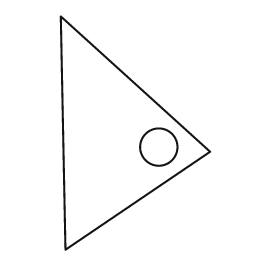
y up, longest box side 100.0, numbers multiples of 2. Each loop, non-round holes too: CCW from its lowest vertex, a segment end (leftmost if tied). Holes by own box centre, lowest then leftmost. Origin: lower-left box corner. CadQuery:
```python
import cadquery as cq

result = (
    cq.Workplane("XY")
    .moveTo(2.0, 0.0)
    .lineTo(64.0, 42.0)
    .lineTo(0.0, 100.0)
    .close()
    .moveTo(42.0, 44.0)
    .circle(8.0)
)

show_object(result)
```